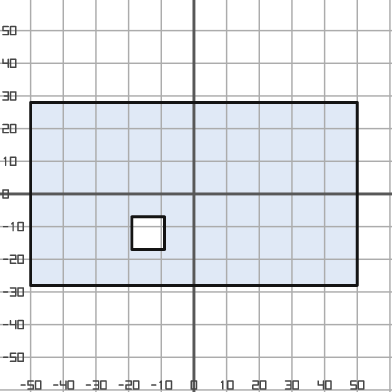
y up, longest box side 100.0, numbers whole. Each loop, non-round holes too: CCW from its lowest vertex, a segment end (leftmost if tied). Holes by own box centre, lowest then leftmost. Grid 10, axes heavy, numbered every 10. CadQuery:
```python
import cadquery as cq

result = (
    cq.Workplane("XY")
    .moveTo(-50.0, -28.0)
    .lineTo(50.0, -28.0)
    .lineTo(50.0, 28.0)
    .lineTo(-50.0, 28.0)
    .close()
    .moveTo(-19.0, -17.0)
    .lineTo(-9.0, -17.0)
    .lineTo(-9.0, -7.0)
    .lineTo(-19.0, -7.0)
    .close()
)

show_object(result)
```